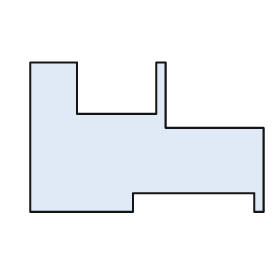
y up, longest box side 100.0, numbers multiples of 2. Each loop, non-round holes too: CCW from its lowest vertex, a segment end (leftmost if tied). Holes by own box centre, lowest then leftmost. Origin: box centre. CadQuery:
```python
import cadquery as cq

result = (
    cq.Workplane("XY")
    .moveTo(-50.0, -32.0)
    .lineTo(-6.0, -32.0)
    .lineTo(-6.0, -24.0)
    .lineTo(46.0, -24.0)
    .lineTo(46.0, -32.0)
    .lineTo(50.0, -32.0)
    .lineTo(50.0, 4.0)
    .lineTo(8.0, 4.0)
    .lineTo(8.0, 32.0)
    .lineTo(4.0, 32.0)
    .lineTo(4.0, 10.0)
    .lineTo(-30.0, 10.0)
    .lineTo(-30.0, 32.0)
    .lineTo(-50.0, 32.0)
    .close()
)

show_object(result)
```